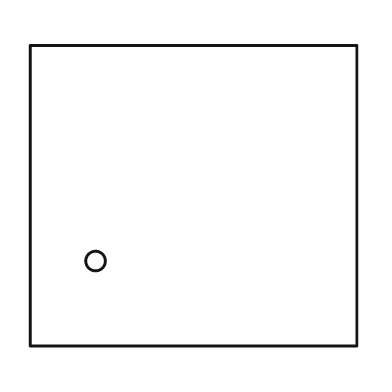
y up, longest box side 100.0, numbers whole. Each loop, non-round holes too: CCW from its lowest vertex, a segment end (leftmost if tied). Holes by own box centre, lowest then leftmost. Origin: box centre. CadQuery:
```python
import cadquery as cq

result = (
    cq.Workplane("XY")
    .moveTo(-50.0, -46.0)
    .lineTo(50.0, -46.0)
    .lineTo(50.0, 46.0)
    .lineTo(-50.0, 46.0)
    .close()
    .moveTo(-30.0, -20.0)
    .circle(3.0)
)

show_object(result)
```